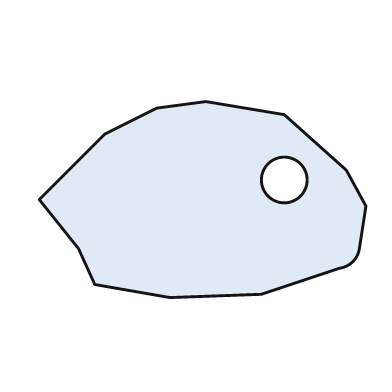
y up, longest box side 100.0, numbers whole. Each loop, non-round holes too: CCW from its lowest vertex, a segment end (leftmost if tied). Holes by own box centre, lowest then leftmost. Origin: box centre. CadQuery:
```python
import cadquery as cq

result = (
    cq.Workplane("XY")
    .moveTo(-10.0, -30.0)
    .lineTo(18.0, -29.0)
    .lineTo(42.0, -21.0)
    .threePointArc((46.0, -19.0), (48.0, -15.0))
    .lineTo(50.0, -2.0)
    .lineTo(44.0, 9.0)
    .lineTo(25.0, 26.0)
    .lineTo(1.0, 30.0)
    .lineTo(-14.0, 28.0)
    .lineTo(-30.0, 20.0)
    .lineTo(-50.0, 0.0)
    .lineTo(-38.0, -15.0)
    .lineTo(-33.0, -26.0)
    .close()
    .moveTo(25.0, 6.0)
    .circle(7.0)
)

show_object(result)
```